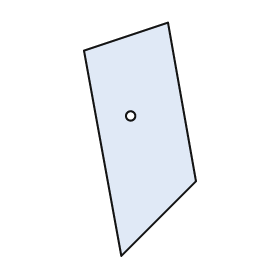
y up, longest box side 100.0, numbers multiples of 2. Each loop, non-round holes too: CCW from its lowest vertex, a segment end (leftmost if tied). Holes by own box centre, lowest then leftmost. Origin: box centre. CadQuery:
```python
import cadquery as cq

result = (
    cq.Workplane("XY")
    .moveTo(-8.0, -50.0)
    .lineTo(24.0, -18.0)
    .lineTo(12.0, 50.0)
    .lineTo(-24.0, 38.0)
    .close()
    .moveTo(-4.0, 10.0)
    .circle(2.0)
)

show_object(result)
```